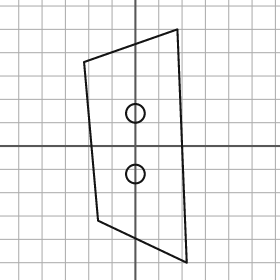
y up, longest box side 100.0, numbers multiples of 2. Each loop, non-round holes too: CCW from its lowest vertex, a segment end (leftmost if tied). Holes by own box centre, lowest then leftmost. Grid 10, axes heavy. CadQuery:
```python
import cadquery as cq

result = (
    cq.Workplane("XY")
    .moveTo(22.0, -50.0)
    .lineTo(18.0, 50.0)
    .lineTo(-22.0, 36.0)
    .lineTo(-16.0, -32.0)
    .close()
    .moveTo(0.0, -12.0)
    .circle(4.0)
    .moveTo(0.0, 14.0)
    .circle(4.0)
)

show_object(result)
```